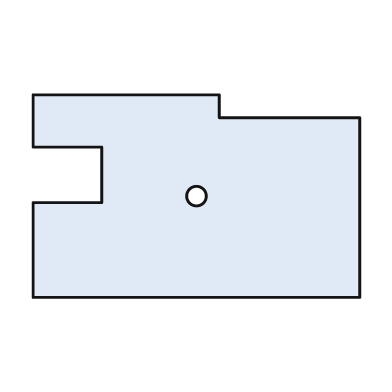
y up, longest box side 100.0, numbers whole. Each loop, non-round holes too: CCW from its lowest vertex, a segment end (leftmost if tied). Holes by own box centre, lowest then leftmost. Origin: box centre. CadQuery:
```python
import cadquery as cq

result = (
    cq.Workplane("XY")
    .moveTo(-50.0, -31.0)
    .lineTo(50.0, -31.0)
    .lineTo(50.0, 24.0)
    .lineTo(7.0, 24.0)
    .lineTo(7.0, 31.0)
    .lineTo(-50.0, 31.0)
    .lineTo(-50.0, 15.0)
    .lineTo(-29.0, 15.0)
    .lineTo(-29.0, -2.0)
    .lineTo(-50.0, -2.0)
    .close()
    .moveTo(0.0, 0.0)
    .circle(3.0)
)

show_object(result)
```